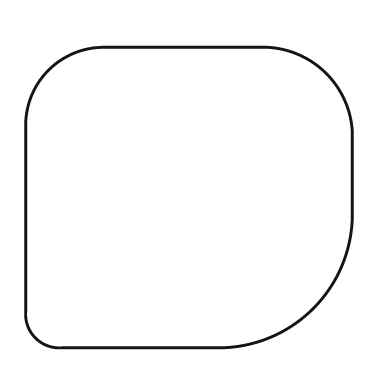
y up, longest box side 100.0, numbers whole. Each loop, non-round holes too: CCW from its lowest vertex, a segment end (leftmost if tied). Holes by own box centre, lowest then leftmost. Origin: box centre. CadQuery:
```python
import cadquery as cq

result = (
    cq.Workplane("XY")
    .moveTo(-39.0, -46.0)
    .lineTo(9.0, -46.0)
    .threePointArc((38.0, -34.0), (50.0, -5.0))
    .lineTo(50.0, 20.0)
    .threePointArc((42.0, 38.0), (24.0, 46.0))
    .lineTo(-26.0, 46.0)
    .threePointArc((-43.0, 39.0), (-50.0, 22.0))
    .lineTo(-50.0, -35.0)
    .threePointArc((-47.0, -43.0), (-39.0, -46.0))
    .close()
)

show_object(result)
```